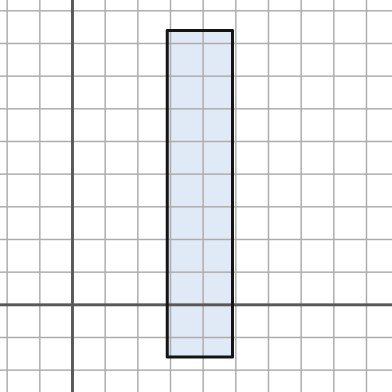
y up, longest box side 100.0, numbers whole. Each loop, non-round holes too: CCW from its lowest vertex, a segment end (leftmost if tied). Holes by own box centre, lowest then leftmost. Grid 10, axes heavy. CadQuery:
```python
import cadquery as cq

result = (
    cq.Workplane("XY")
    .moveTo(29.0, -16.0)
    .lineTo(49.0, -16.0)
    .lineTo(49.0, 84.0)
    .lineTo(29.0, 84.0)
    .close()
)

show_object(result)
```